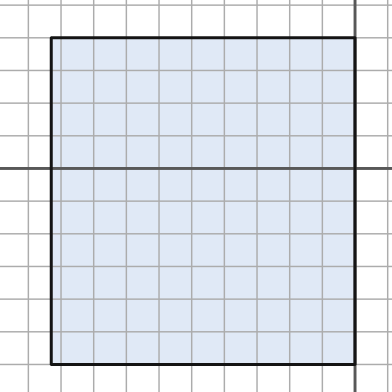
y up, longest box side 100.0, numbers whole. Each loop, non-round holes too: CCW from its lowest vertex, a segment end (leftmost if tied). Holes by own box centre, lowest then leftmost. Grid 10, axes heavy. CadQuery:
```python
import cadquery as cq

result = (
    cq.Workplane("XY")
    .moveTo(-93.0, -60.0)
    .lineTo(0.0, -60.0)
    .lineTo(0.0, 40.0)
    .lineTo(-93.0, 40.0)
    .close()
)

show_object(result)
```